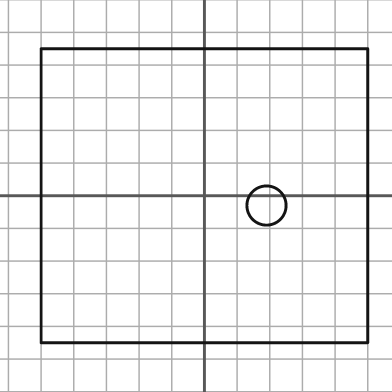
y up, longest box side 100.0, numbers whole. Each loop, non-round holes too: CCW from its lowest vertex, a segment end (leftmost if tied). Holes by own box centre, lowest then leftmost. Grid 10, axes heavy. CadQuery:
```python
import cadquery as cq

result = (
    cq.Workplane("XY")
    .moveTo(-50.0, -45.0)
    .lineTo(50.0, -45.0)
    .lineTo(50.0, 45.0)
    .lineTo(-50.0, 45.0)
    .close()
    .moveTo(19.0, -3.0)
    .circle(6.0)
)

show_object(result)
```